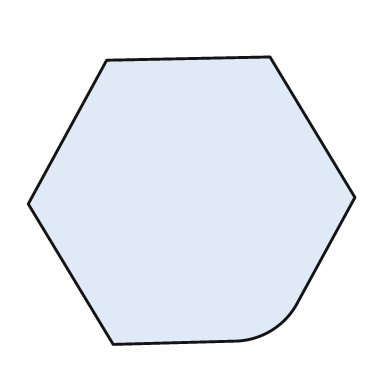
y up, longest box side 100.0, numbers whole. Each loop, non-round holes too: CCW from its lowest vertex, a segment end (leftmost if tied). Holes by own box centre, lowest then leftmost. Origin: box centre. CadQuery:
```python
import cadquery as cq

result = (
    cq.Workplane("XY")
    .moveTo(-24.0, -44.0)
    .lineTo(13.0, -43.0)
    .threePointArc((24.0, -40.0), (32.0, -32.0))
    .lineTo(50.0, 1.0)
    .lineTo(24.0, 44.0)
    .lineTo(-26.0, 43.0)
    .lineTo(-50.0, -1.0)
    .close()
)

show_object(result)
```